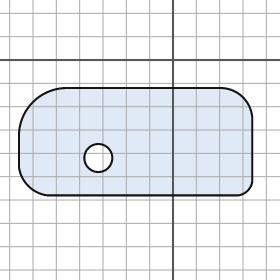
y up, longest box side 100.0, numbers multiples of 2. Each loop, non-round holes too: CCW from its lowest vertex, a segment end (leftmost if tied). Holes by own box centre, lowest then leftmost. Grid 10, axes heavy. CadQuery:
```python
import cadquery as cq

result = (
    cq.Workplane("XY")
    .moveTo(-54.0, -58.0)
    .lineTo(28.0, -58.0)
    .threePointArc((32.0, -56.0), (34.0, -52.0))
    .lineTo(34.0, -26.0)
    .threePointArc((30.0, -16.0), (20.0, -12.0))
    .lineTo(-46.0, -12.0)
    .threePointArc((-60.0, -18.0), (-66.0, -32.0))
    .lineTo(-66.0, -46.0)
    .threePointArc((-62.0, -54.0), (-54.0, -58.0))
    .close()
    .moveTo(-32.0, -42.0)
    .circle(6.0)
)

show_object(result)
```